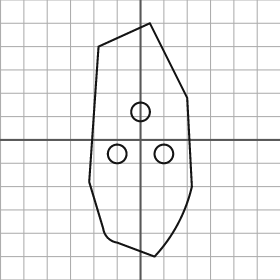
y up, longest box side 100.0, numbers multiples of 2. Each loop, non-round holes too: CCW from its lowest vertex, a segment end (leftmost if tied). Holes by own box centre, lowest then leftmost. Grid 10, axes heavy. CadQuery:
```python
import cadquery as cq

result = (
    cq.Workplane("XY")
    .moveTo(6.0, -50.0)
    .threePointArc((16.0, -36.0), (22.0, -20.0))
    .lineTo(20.0, 18.0)
    .lineTo(4.0, 50.0)
    .lineTo(-18.0, 40.0)
    .lineTo(-22.0, -18.0)
    .lineTo(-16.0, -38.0)
    .threePointArc((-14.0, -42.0), (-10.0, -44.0))
    .close()
    .moveTo(-10.0, -6.0)
    .circle(4.0)
    .moveTo(10.0, -6.0)
    .circle(4.0)
    .moveTo(0.0, 12.0)
    .circle(4.0)
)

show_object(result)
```